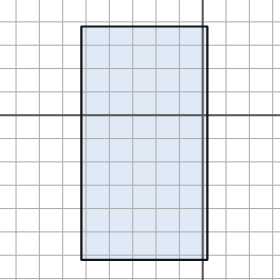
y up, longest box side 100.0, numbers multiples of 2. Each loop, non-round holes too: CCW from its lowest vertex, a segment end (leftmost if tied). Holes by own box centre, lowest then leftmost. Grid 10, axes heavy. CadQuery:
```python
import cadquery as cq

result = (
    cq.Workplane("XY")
    .moveTo(-52.0, -62.0)
    .lineTo(2.0, -62.0)
    .lineTo(2.0, 38.0)
    .lineTo(-52.0, 38.0)
    .close()
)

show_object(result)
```